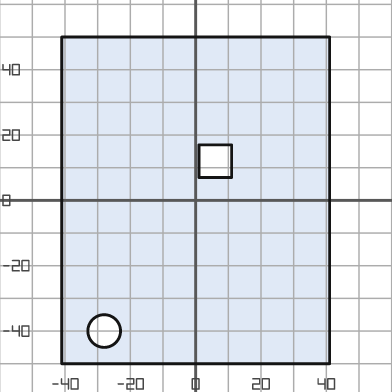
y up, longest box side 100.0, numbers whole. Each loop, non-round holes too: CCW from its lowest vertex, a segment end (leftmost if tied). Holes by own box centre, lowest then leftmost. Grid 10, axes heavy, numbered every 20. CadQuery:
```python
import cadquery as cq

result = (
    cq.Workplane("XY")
    .moveTo(-41.0, -50.0)
    .lineTo(41.0, -50.0)
    .lineTo(41.0, 50.0)
    .lineTo(-41.0, 50.0)
    .close()
    .moveTo(-28.0, -40.0)
    .circle(5.0)
    .moveTo(1.0, 7.0)
    .lineTo(11.0, 7.0)
    .lineTo(11.0, 17.0)
    .lineTo(1.0, 17.0)
    .close()
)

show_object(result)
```